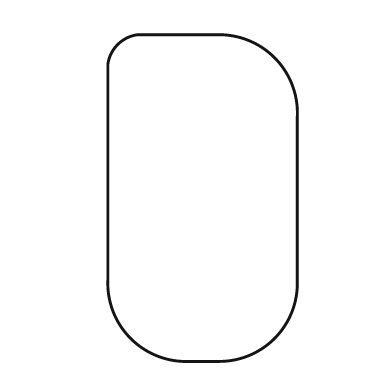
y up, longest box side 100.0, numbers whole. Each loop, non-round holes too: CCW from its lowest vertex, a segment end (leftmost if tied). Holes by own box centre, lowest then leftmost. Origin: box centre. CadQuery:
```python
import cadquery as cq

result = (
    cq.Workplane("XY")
    .moveTo(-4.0, -50.0)
    .lineTo(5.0, -50.0)
    .threePointArc((22.0, -43.0), (29.0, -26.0))
    .lineTo(29.0, 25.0)
    .threePointArc((22.0, 43.0), (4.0, 50.0))
    .lineTo(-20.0, 50.0)
    .threePointArc((-26.0, 47.0), (-29.0, 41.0))
    .lineTo(-29.0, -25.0)
    .threePointArc((-22.0, -43.0), (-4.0, -50.0))
    .close()
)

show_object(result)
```